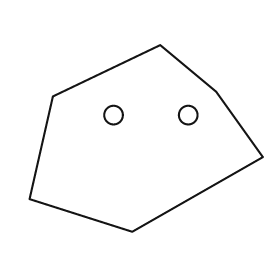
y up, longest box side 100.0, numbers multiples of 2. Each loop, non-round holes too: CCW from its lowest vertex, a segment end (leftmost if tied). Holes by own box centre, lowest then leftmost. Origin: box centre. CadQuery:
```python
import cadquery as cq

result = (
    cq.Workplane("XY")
    .moveTo(-6.0, -40.0)
    .lineTo(50.0, -8.0)
    .lineTo(30.0, 20.0)
    .lineTo(6.0, 40.0)
    .lineTo(-40.0, 18.0)
    .lineTo(-50.0, -26.0)
    .close()
    .moveTo(-14.0, 10.0)
    .circle(4.0)
    .moveTo(18.0, 10.0)
    .circle(4.0)
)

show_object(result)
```